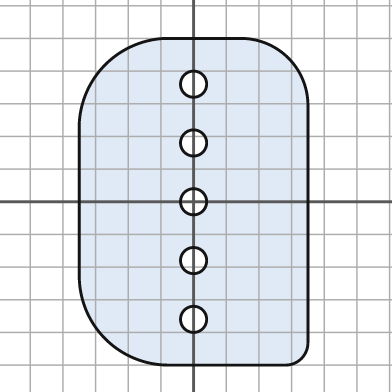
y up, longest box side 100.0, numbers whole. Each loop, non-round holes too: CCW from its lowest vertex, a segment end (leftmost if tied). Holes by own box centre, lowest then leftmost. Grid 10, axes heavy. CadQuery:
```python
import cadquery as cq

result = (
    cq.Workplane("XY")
    .moveTo(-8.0, -50.0)
    .lineTo(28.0, -50.0)
    .threePointArc((33.0, -48.0), (35.0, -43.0))
    .lineTo(35.0, 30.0)
    .threePointArc((29.0, 44.0), (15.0, 50.0))
    .lineTo(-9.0, 50.0)
    .threePointArc((-27.0, 42.0), (-35.0, 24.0))
    .lineTo(-35.0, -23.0)
    .threePointArc((-27.0, -42.0), (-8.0, -50.0))
    .close()
    .moveTo(0.0, -36.0)
    .circle(4.0)
    .moveTo(0.0, -18.0)
    .circle(4.0)
    .moveTo(0.0, 0.0)
    .circle(4.0)
    .moveTo(0.0, 18.0)
    .circle(4.0)
    .moveTo(0.0, 36.0)
    .circle(4.0)
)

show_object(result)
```